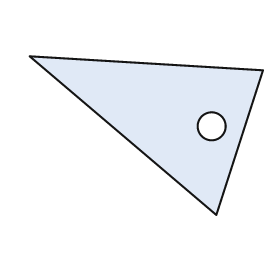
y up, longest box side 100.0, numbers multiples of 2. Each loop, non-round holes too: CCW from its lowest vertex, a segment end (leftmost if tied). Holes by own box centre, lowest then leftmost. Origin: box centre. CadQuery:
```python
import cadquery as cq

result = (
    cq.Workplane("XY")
    .moveTo(30.0, -34.0)
    .lineTo(50.0, 28.0)
    .lineTo(-50.0, 34.0)
    .close()
    .moveTo(28.0, 4.0)
    .circle(6.0)
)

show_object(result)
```